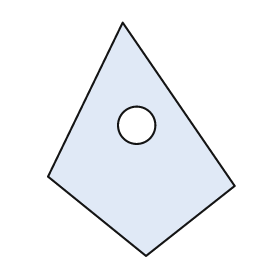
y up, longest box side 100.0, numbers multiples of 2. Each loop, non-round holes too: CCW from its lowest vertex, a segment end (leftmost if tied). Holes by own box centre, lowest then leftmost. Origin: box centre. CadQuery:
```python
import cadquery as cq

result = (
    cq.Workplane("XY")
    .moveTo(2.0, -50.0)
    .lineTo(40.0, -20.0)
    .lineTo(-8.0, 50.0)
    .lineTo(-40.0, -16.0)
    .close()
    .moveTo(-2.0, 6.0)
    .circle(8.0)
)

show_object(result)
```